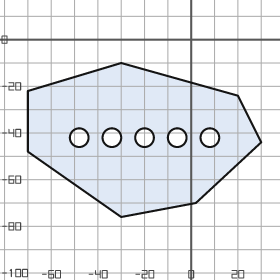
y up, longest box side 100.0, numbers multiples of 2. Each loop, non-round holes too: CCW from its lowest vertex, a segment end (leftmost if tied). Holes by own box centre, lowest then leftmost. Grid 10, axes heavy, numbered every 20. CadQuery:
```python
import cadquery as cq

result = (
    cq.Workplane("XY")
    .moveTo(-30.0, -76.0)
    .lineTo(2.0, -70.0)
    .lineTo(30.0, -44.0)
    .lineTo(20.0, -24.0)
    .lineTo(-30.0, -10.0)
    .lineTo(-70.0, -22.0)
    .lineTo(-70.0, -48.0)
    .close()
    .moveTo(-48.0, -42.0)
    .circle(4.0)
    .moveTo(-34.0, -42.0)
    .circle(4.0)
    .moveTo(-20.0, -42.0)
    .circle(4.0)
    .moveTo(-6.0, -42.0)
    .circle(4.0)
    .moveTo(8.0, -42.0)
    .circle(4.0)
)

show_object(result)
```